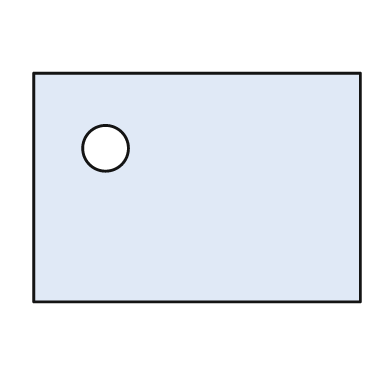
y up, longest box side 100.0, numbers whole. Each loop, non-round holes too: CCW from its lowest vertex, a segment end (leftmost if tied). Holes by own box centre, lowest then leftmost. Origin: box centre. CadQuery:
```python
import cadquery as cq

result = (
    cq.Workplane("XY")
    .moveTo(-50.0, -35.0)
    .lineTo(50.0, -35.0)
    .lineTo(50.0, 35.0)
    .lineTo(-50.0, 35.0)
    .close()
    .moveTo(-28.0, 12.0)
    .circle(7.0)
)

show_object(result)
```